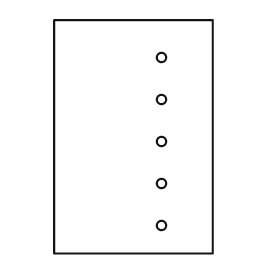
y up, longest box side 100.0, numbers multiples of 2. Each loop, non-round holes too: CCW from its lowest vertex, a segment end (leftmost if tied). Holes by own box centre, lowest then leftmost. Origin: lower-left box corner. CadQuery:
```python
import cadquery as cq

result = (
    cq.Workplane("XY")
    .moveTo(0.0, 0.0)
    .lineTo(68.0, 0.0)
    .lineTo(68.0, 100.0)
    .lineTo(0.0, 100.0)
    .close()
    .moveTo(46.0, 12.0)
    .circle(2.0)
    .moveTo(46.0, 30.0)
    .circle(2.0)
    .moveTo(46.0, 48.0)
    .circle(2.0)
    .moveTo(46.0, 66.0)
    .circle(2.0)
    .moveTo(46.0, 84.0)
    .circle(2.0)
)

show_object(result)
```